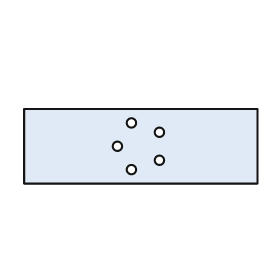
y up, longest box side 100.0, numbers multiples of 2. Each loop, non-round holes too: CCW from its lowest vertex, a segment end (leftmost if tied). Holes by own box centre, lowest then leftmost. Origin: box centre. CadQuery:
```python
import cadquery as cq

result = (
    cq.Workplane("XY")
    .moveTo(-50.0, -16.0)
    .lineTo(50.0, -16.0)
    .lineTo(50.0, 16.0)
    .lineTo(-50.0, 16.0)
    .close()
    .moveTo(-4.0, -10.0)
    .circle(2.0)
    .moveTo(8.0, -6.0)
    .circle(2.0)
    .moveTo(-10.0, 0.0)
    .circle(2.0)
    .moveTo(8.0, 6.0)
    .circle(2.0)
    .moveTo(-4.0, 10.0)
    .circle(2.0)
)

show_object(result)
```